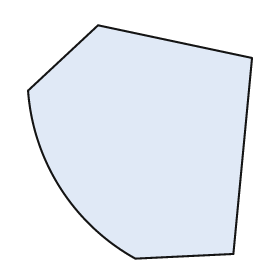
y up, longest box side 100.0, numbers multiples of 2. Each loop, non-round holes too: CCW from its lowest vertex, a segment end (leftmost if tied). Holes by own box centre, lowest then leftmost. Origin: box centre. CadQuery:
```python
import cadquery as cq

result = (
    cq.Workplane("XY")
    .moveTo(-2.0, -50.0)
    .lineTo(40.0, -48.0)
    .lineTo(48.0, 36.0)
    .lineTo(-18.0, 50.0)
    .lineTo(-48.0, 22.0)
    .threePointArc((-34.0, -20.0), (-2.0, -50.0))
    .close()
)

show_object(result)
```